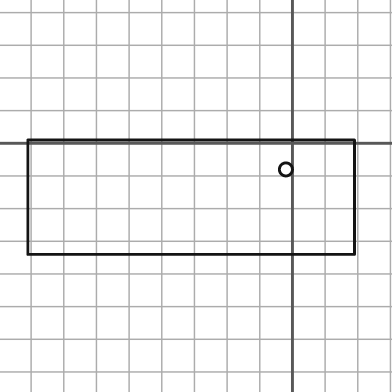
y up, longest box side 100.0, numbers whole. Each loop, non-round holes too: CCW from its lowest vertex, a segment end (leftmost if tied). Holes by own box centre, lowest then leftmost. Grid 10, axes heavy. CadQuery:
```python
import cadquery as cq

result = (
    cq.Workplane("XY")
    .moveTo(-81.0, -34.0)
    .lineTo(19.0, -34.0)
    .lineTo(19.0, 1.0)
    .lineTo(-81.0, 1.0)
    .close()
    .moveTo(-2.0, -8.0)
    .circle(2.0)
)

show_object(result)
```